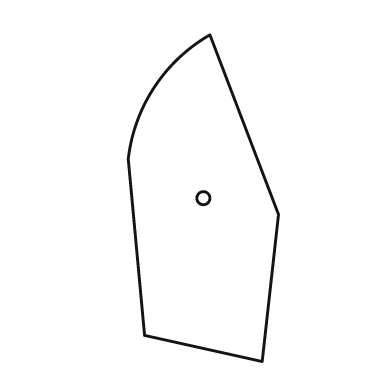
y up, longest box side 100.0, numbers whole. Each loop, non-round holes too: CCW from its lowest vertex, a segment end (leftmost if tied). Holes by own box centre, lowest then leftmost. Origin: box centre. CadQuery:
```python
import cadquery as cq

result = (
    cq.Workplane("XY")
    .moveTo(18.0, -50.0)
    .lineTo(23.0, -5.0)
    .lineTo(2.0, 50.0)
    .threePointArc((-15.0, 34.0), (-23.0, 12.0))
    .lineTo(-18.0, -42.0)
    .close()
    .moveTo(0.0, 0.0)
    .circle(2.0)
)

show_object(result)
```